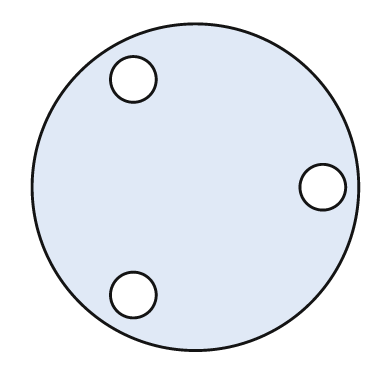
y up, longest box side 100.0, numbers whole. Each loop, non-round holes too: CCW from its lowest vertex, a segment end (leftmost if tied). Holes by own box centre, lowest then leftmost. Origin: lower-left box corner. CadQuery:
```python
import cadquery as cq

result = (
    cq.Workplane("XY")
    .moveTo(50.0, 50.0)
    .circle(50.0)
    .moveTo(31.0, 17.0)
    .circle(7.0)
    .moveTo(89.0, 50.0)
    .circle(7.0)
    .moveTo(31.0, 83.0)
    .circle(7.0)
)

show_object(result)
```